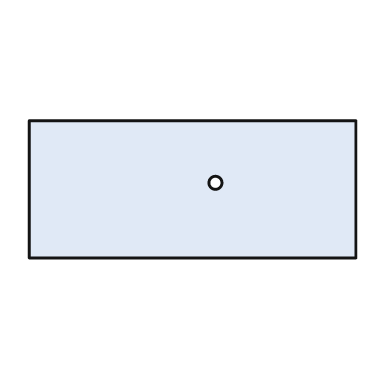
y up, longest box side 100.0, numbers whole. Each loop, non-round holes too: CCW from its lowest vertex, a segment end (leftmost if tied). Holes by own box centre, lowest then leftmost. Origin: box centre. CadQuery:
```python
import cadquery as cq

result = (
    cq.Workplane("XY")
    .moveTo(-50.0, -21.0)
    .lineTo(50.0, -21.0)
    .lineTo(50.0, 21.0)
    .lineTo(-50.0, 21.0)
    .close()
    .moveTo(7.0, 2.0)
    .circle(2.0)
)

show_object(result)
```